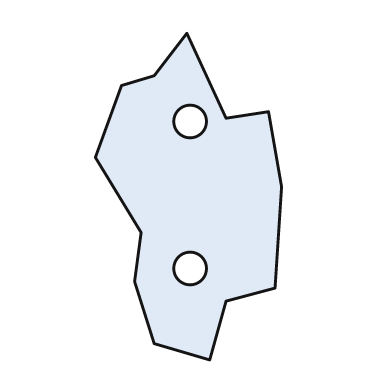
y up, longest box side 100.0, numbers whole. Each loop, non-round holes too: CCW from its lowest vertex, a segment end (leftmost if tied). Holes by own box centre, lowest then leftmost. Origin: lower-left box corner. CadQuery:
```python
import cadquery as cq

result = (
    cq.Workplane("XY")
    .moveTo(35.0, 0.0)
    .lineTo(40.0, 18.0)
    .lineTo(55.0, 22.0)
    .lineTo(57.0, 53.0)
    .lineTo(53.0, 76.0)
    .lineTo(40.0, 74.0)
    .lineTo(28.0, 100.0)
    .lineTo(18.0, 87.0)
    .lineTo(8.0, 84.0)
    .lineTo(0.0, 62.0)
    .lineTo(14.0, 39.0)
    .lineTo(12.0, 24.0)
    .lineTo(18.0, 5.0)
    .close()
    .moveTo(29.0, 28.0)
    .circle(5.0)
    .moveTo(29.0, 73.0)
    .circle(5.0)
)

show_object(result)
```